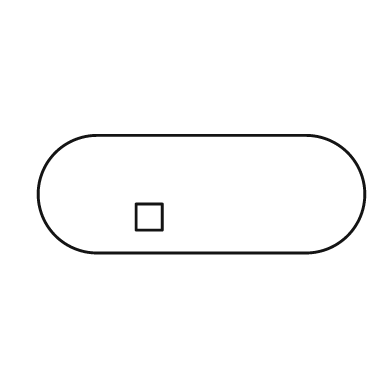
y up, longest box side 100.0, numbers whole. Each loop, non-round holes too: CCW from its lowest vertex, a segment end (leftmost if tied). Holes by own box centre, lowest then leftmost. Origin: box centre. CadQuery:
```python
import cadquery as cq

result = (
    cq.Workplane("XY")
    .moveTo(-32.0, -18.0)
    .lineTo(32.0, -18.0)
    .threePointArc((50.0, 0.0), (32.0, 18.0))
    .lineTo(-32.0, 18.0)
    .threePointArc((-50.0, 0.0), (-32.0, -18.0))
    .close()
    .moveTo(-20.0, -11.0)
    .lineTo(-12.0, -11.0)
    .lineTo(-12.0, -3.0)
    .lineTo(-20.0, -3.0)
    .close()
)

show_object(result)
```